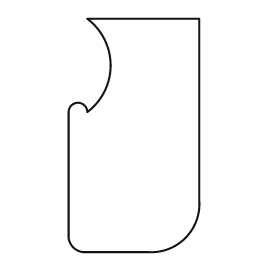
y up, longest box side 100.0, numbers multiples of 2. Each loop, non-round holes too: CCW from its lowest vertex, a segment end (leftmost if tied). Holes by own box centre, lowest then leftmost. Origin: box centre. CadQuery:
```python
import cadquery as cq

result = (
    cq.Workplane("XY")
    .moveTo(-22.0, -50.0)
    .lineTo(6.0, -50.0)
    .threePointArc((22.0, -44.0), (28.0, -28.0))
    .lineTo(28.0, 50.0)
    .lineTo(-20.0, 50.0)
    .threePointArc((-10.0, 30.0), (-20.0, 10.0))
    .threePointArc((-24.0, 14.0), (-28.0, 10.0))
    .lineTo(-28.0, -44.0)
    .threePointArc((-26.0, -48.0), (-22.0, -50.0))
    .close()
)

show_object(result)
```